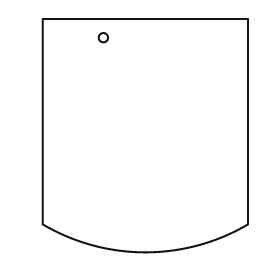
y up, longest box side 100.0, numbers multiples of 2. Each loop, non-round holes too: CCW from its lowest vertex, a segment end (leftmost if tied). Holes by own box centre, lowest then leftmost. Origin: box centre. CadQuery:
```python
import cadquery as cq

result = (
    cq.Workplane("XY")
    .moveTo(-44.0, -38.0)
    .threePointArc((0.0, -50.0), (44.0, -38.0))
    .lineTo(44.0, 50.0)
    .lineTo(-44.0, 50.0)
    .close()
    .moveTo(-18.0, 42.0)
    .circle(2.0)
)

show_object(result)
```